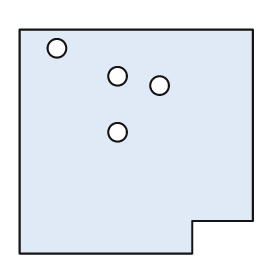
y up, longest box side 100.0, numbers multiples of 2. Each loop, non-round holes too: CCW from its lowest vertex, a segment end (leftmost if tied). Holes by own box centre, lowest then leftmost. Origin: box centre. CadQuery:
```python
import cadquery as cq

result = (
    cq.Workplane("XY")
    .moveTo(-50.0, -48.0)
    .lineTo(24.0, -48.0)
    .lineTo(24.0, -34.0)
    .lineTo(50.0, -34.0)
    .lineTo(50.0, 48.0)
    .lineTo(-50.0, 48.0)
    .close()
    .moveTo(-8.0, 4.0)
    .circle(4.0)
    .moveTo(10.0, 24.0)
    .circle(4.0)
    .moveTo(-8.0, 28.0)
    .circle(4.0)
    .moveTo(-34.0, 40.0)
    .circle(4.0)
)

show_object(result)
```